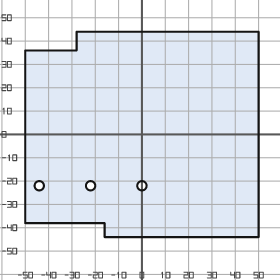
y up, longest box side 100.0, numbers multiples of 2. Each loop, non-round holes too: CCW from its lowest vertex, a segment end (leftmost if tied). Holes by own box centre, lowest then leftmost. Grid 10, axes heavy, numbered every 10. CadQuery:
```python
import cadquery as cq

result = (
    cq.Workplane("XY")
    .moveTo(-16.0, -44.0)
    .lineTo(50.0, -44.0)
    .lineTo(50.0, 44.0)
    .lineTo(-28.0, 44.0)
    .lineTo(-28.0, 36.0)
    .lineTo(-50.0, 36.0)
    .lineTo(-50.0, -38.0)
    .lineTo(-16.0, -38.0)
    .close()
    .moveTo(-44.0, -22.0)
    .circle(2.0)
    .moveTo(-22.0, -22.0)
    .circle(2.0)
    .moveTo(0.0, -22.0)
    .circle(2.0)
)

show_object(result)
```